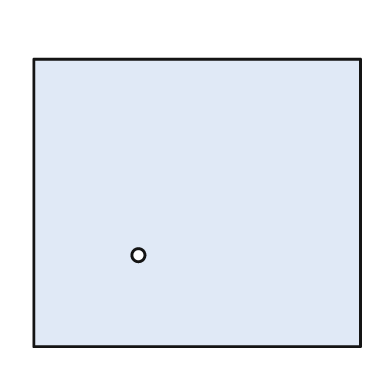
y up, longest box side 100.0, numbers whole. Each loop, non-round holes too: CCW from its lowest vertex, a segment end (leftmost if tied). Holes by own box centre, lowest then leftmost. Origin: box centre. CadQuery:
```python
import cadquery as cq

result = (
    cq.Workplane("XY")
    .moveTo(-50.0, -44.0)
    .lineTo(50.0, -44.0)
    .lineTo(50.0, 44.0)
    .lineTo(-50.0, 44.0)
    .close()
    .moveTo(-18.0, -16.0)
    .circle(2.0)
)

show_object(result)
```